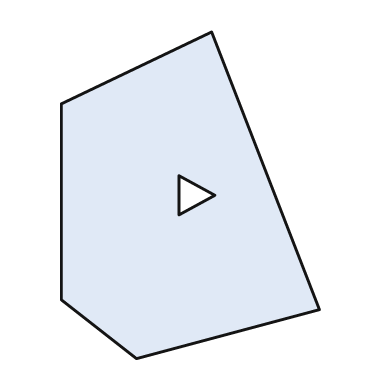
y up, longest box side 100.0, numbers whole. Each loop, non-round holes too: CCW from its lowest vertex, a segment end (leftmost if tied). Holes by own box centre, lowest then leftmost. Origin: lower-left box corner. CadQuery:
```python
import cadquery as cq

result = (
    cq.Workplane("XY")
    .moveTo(23.0, 0.0)
    .lineTo(79.0, 15.0)
    .lineTo(46.0, 100.0)
    .lineTo(0.0, 78.0)
    .lineTo(0.0, 18.0)
    .close()
    .moveTo(36.0, 44.0)
    .lineTo(47.0, 50.0)
    .lineTo(36.0, 56.0)
    .close()
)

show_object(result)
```